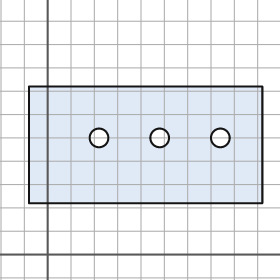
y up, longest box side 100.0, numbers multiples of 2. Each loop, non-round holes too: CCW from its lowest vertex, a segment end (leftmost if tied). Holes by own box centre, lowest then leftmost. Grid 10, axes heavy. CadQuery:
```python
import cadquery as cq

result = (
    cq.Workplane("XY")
    .moveTo(-8.0, 22.0)
    .lineTo(92.0, 22.0)
    .lineTo(92.0, 72.0)
    .lineTo(-8.0, 72.0)
    .close()
    .moveTo(22.0, 50.0)
    .circle(4.0)
    .moveTo(48.0, 50.0)
    .circle(4.0)
    .moveTo(74.0, 50.0)
    .circle(4.0)
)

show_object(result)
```